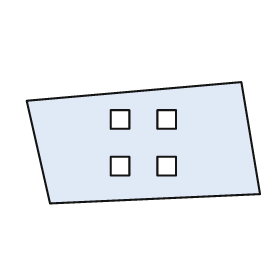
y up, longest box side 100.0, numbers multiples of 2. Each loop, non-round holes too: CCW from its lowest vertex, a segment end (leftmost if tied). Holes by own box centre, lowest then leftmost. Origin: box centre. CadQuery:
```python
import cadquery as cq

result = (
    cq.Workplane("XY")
    .moveTo(-40.0, -26.0)
    .lineTo(50.0, -22.0)
    .lineTo(42.0, 26.0)
    .lineTo(-50.0, 18.0)
    .close()
    .moveTo(-14.0, -14.0)
    .lineTo(-6.0, -14.0)
    .lineTo(-6.0, -6.0)
    .lineTo(-14.0, -6.0)
    .close()
    .moveTo(6.0, -14.0)
    .lineTo(14.0, -14.0)
    .lineTo(14.0, -6.0)
    .lineTo(6.0, -6.0)
    .close()
    .moveTo(-14.0, 6.0)
    .lineTo(-6.0, 6.0)
    .lineTo(-6.0, 14.0)
    .lineTo(-14.0, 14.0)
    .close()
    .moveTo(6.0, 6.0)
    .lineTo(14.0, 6.0)
    .lineTo(14.0, 14.0)
    .lineTo(6.0, 14.0)
    .close()
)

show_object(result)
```